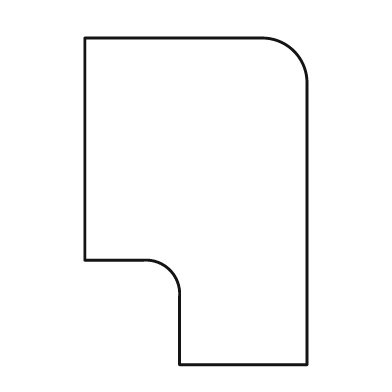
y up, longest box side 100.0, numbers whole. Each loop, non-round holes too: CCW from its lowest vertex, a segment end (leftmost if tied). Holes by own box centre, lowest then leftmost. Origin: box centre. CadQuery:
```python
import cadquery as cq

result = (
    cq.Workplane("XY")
    .moveTo(-5.0, -50.0)
    .lineTo(34.0, -50.0)
    .lineTo(34.0, 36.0)
    .threePointArc((30.0, 46.0), (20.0, 50.0))
    .lineTo(-34.0, 50.0)
    .lineTo(-34.0, -18.0)
    .lineTo(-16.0, -18.0)
    .threePointArc((-8.0, -21.0), (-5.0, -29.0))
    .close()
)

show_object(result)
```